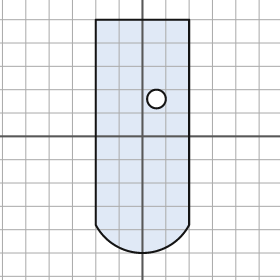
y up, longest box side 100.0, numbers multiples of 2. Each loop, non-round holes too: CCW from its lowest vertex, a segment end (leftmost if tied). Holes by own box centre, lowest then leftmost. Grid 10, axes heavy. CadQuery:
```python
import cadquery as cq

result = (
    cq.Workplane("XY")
    .moveTo(-20.0, -38.0)
    .threePointArc((0.0, -50.0), (20.0, -38.0))
    .lineTo(20.0, 50.0)
    .lineTo(-20.0, 50.0)
    .close()
    .moveTo(6.0, 16.0)
    .circle(4.0)
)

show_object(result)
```